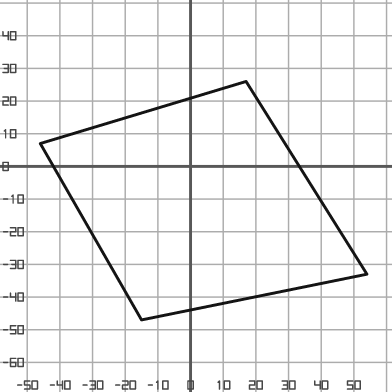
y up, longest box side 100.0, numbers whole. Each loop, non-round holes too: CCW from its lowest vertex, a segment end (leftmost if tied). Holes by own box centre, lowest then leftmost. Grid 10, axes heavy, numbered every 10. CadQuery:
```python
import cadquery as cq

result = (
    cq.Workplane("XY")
    .moveTo(-15.0, -47.0)
    .lineTo(54.0, -33.0)
    .lineTo(17.0, 26.0)
    .lineTo(-46.0, 7.0)
    .close()
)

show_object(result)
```